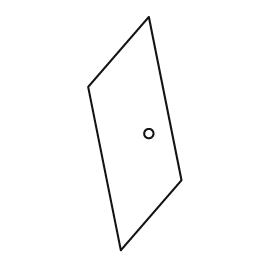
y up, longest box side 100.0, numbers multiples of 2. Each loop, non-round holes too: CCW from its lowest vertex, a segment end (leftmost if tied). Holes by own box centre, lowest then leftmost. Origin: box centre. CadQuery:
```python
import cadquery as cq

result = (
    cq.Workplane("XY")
    .moveTo(-6.0, -50.0)
    .lineTo(20.0, -20.0)
    .lineTo(6.0, 50.0)
    .lineTo(-20.0, 20.0)
    .close()
    .moveTo(6.0, 0.0)
    .circle(2.0)
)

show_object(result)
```